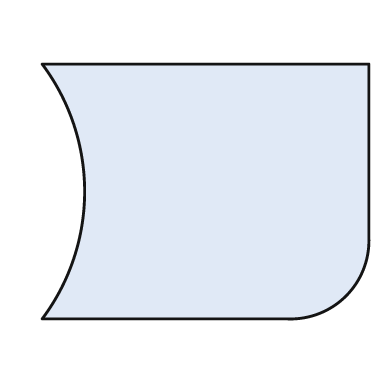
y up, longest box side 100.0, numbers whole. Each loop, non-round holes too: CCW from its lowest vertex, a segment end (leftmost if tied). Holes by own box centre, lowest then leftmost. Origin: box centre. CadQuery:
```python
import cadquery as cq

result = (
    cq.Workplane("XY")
    .moveTo(-50.0, -39.0)
    .lineTo(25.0, -39.0)
    .threePointArc((43.0, -32.0), (50.0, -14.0))
    .lineTo(50.0, 39.0)
    .lineTo(-50.0, 39.0)
    .threePointArc((-37.0, 0.0), (-50.0, -39.0))
    .close()
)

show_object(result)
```